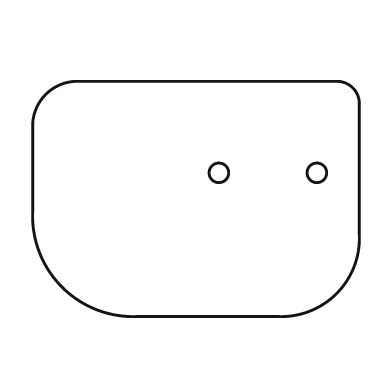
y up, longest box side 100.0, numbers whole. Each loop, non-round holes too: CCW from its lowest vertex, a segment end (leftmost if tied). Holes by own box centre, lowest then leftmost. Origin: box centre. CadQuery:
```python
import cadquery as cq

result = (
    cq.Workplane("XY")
    .moveTo(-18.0, -36.0)
    .lineTo(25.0, -36.0)
    .threePointArc((43.0, -29.0), (50.0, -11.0))
    .lineTo(50.0, 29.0)
    .threePointArc((48.0, 34.0), (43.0, 36.0))
    .lineTo(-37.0, 36.0)
    .threePointArc((-46.0, 32.0), (-50.0, 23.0))
    .lineTo(-50.0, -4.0)
    .threePointArc((-41.0, -27.0), (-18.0, -36.0))
    .close()
    .moveTo(7.0, 8.0)
    .circle(3.0)
    .moveTo(37.0, 8.0)
    .circle(3.0)
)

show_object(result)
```